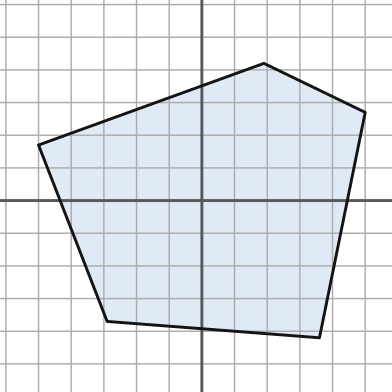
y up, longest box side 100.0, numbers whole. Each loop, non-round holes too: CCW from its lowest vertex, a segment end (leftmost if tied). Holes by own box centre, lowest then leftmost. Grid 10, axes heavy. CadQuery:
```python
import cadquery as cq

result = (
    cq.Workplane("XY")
    .moveTo(36.0, -42.0)
    .lineTo(50.0, 27.0)
    .lineTo(19.0, 42.0)
    .lineTo(-50.0, 17.0)
    .lineTo(-29.0, -37.0)
    .close()
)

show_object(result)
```